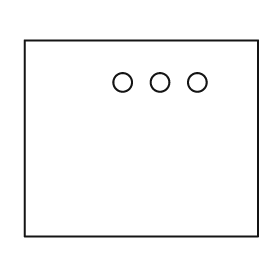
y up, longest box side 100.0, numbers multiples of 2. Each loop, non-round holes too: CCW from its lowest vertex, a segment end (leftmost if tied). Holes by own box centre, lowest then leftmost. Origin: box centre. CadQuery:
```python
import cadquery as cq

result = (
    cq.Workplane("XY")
    .moveTo(-50.0, -42.0)
    .lineTo(50.0, -42.0)
    .lineTo(50.0, 42.0)
    .lineTo(-50.0, 42.0)
    .close()
    .moveTo(-8.0, 24.0)
    .circle(4.0)
    .moveTo(8.0, 24.0)
    .circle(4.0)
    .moveTo(24.0, 24.0)
    .circle(4.0)
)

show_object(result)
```